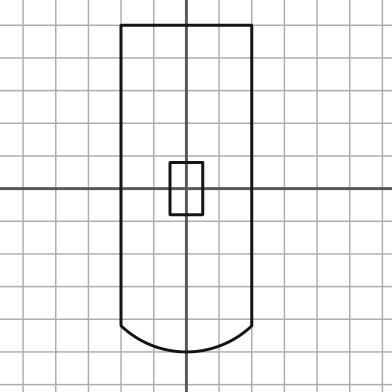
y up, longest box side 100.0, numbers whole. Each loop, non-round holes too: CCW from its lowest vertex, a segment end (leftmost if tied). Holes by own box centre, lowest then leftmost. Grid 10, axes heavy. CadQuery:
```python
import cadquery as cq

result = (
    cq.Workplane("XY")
    .moveTo(-20.0, -42.0)
    .threePointArc((0.0, -50.0), (20.0, -42.0))
    .lineTo(20.0, 50.0)
    .lineTo(-20.0, 50.0)
    .close()
    .moveTo(-5.0, -8.0)
    .lineTo(5.0, -8.0)
    .lineTo(5.0, 8.0)
    .lineTo(-5.0, 8.0)
    .close()
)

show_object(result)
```